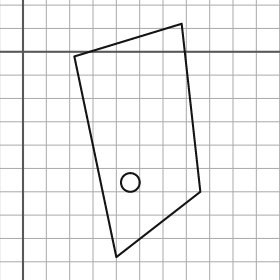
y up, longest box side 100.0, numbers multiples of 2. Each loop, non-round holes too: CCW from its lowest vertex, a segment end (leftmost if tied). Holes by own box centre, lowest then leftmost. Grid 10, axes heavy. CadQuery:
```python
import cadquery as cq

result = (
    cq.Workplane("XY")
    .moveTo(40.0, -88.0)
    .lineTo(76.0, -60.0)
    .lineTo(68.0, 12.0)
    .lineTo(22.0, -2.0)
    .close()
    .moveTo(46.0, -56.0)
    .circle(4.0)
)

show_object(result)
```